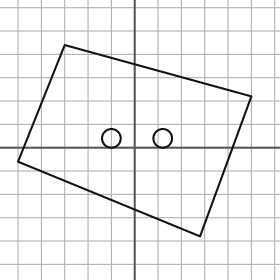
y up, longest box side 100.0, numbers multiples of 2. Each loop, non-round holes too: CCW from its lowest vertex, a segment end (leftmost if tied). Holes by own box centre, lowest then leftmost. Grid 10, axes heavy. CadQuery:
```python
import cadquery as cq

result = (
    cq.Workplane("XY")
    .moveTo(28.0, -38.0)
    .lineTo(50.0, 22.0)
    .lineTo(-30.0, 44.0)
    .lineTo(-50.0, -6.0)
    .close()
    .moveTo(-10.0, 4.0)
    .circle(4.0)
    .moveTo(12.0, 4.0)
    .circle(4.0)
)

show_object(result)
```